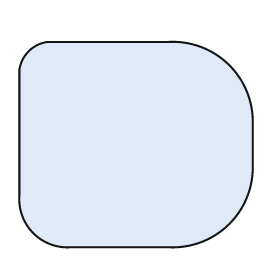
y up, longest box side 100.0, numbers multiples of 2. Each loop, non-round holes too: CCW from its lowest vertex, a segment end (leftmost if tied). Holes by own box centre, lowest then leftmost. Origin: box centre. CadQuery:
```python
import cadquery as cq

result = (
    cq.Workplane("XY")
    .moveTo(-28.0, -44.0)
    .lineTo(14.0, -44.0)
    .threePointArc((40.0, -34.0), (50.0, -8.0))
    .lineTo(50.0, 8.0)
    .threePointArc((40.0, 34.0), (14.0, 44.0))
    .lineTo(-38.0, 44.0)
    .threePointArc((-46.0, 40.0), (-50.0, 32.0))
    .lineTo(-50.0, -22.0)
    .threePointArc((-44.0, -38.0), (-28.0, -44.0))
    .close()
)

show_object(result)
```